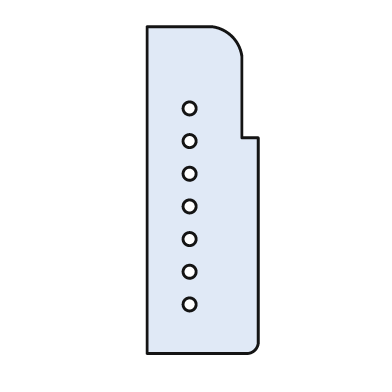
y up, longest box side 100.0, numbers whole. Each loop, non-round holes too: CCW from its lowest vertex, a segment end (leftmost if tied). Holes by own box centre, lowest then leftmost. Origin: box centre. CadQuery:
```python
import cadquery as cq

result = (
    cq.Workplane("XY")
    .moveTo(-17.0, -50.0)
    .lineTo(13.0, -50.0)
    .threePointArc((16.0, -49.0), (17.0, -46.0))
    .lineTo(17.0, 16.0)
    .lineTo(12.0, 16.0)
    .lineTo(12.0, 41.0)
    .threePointArc((9.0, 47.0), (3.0, 50.0))
    .lineTo(-17.0, 50.0)
    .close()
    .moveTo(-4.0, -35.0)
    .circle(2.0)
    .moveTo(-4.0, -25.0)
    .circle(2.0)
    .moveTo(-4.0, -15.0)
    .circle(2.0)
    .moveTo(-4.0, -5.0)
    .circle(2.0)
    .moveTo(-4.0, 5.0)
    .circle(2.0)
    .moveTo(-4.0, 15.0)
    .circle(2.0)
    .moveTo(-4.0, 25.0)
    .circle(2.0)
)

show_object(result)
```